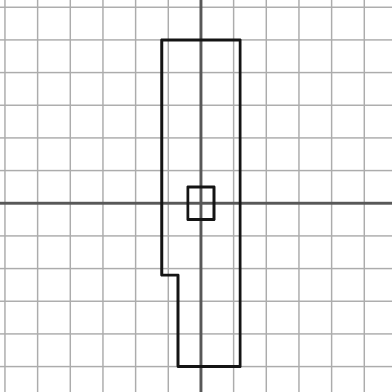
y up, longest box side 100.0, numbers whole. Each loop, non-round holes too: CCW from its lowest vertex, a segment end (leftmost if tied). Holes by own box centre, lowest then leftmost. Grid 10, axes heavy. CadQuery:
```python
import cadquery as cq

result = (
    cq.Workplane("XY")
    .moveTo(-7.0, -50.0)
    .lineTo(12.0, -50.0)
    .lineTo(12.0, 50.0)
    .lineTo(-12.0, 50.0)
    .lineTo(-12.0, -22.0)
    .lineTo(-7.0, -22.0)
    .close()
    .moveTo(-4.0, -5.0)
    .lineTo(4.0, -5.0)
    .lineTo(4.0, 5.0)
    .lineTo(-4.0, 5.0)
    .close()
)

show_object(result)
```